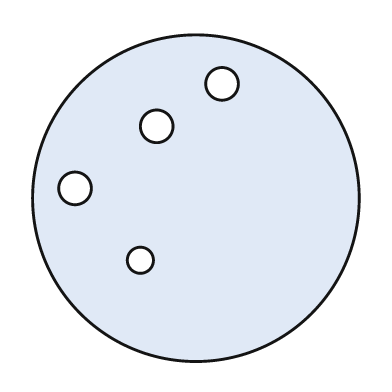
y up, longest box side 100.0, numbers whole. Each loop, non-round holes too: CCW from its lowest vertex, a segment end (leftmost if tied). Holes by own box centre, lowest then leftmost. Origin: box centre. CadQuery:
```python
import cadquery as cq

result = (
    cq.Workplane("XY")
    .moveTo(0.0, 0.0)
    .circle(50.0)
    .moveTo(-17.0, -19.0)
    .circle(4.0)
    .moveTo(-37.0, 3.0)
    .circle(5.0)
    .moveTo(-12.0, 22.0)
    .circle(5.0)
    .moveTo(8.0, 35.0)
    .circle(5.0)
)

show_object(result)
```